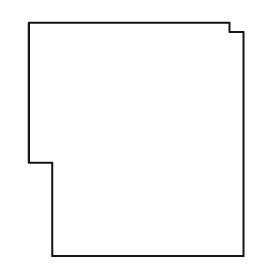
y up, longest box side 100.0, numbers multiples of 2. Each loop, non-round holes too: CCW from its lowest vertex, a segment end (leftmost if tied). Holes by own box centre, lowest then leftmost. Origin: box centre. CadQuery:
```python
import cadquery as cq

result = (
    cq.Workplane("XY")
    .moveTo(-36.0, -50.0)
    .lineTo(46.0, -50.0)
    .lineTo(46.0, 46.0)
    .lineTo(40.0, 46.0)
    .lineTo(40.0, 50.0)
    .lineTo(-46.0, 50.0)
    .lineTo(-46.0, -10.0)
    .lineTo(-36.0, -10.0)
    .close()
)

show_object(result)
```